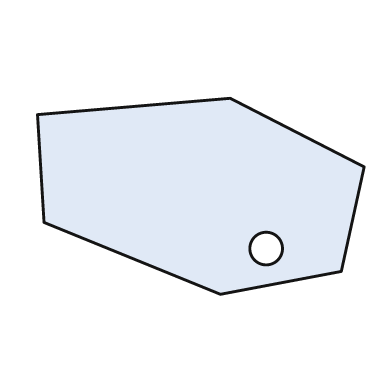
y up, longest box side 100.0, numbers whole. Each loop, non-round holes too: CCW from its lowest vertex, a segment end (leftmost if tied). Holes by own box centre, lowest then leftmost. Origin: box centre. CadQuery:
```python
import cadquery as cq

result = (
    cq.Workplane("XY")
    .moveTo(6.0, -30.0)
    .lineTo(43.0, -23.0)
    .lineTo(50.0, 9.0)
    .lineTo(9.0, 30.0)
    .lineTo(-50.0, 25.0)
    .lineTo(-48.0, -8.0)
    .close()
    .moveTo(20.0, -16.0)
    .circle(5.0)
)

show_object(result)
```